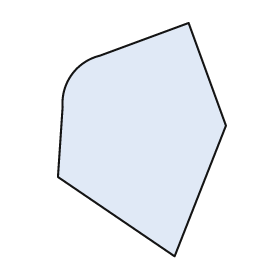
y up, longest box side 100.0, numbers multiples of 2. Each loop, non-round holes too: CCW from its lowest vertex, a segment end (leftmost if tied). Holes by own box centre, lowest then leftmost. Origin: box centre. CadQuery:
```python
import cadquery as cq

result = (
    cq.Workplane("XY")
    .moveTo(14.0, -50.0)
    .lineTo(36.0, 6.0)
    .lineTo(20.0, 50.0)
    .lineTo(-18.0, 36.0)
    .threePointArc((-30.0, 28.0), (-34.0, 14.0))
    .lineTo(-36.0, -16.0)
    .close()
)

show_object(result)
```